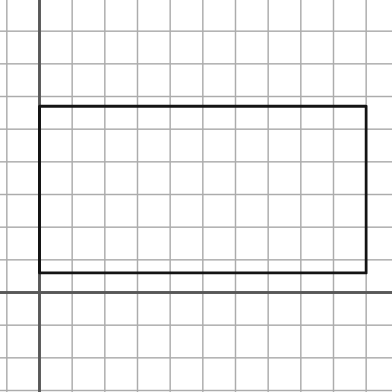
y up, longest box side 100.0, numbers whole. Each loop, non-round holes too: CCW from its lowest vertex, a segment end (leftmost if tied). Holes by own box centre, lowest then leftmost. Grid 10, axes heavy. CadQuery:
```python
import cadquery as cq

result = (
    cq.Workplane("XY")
    .moveTo(0.0, 6.0)
    .lineTo(100.0, 6.0)
    .lineTo(100.0, 57.0)
    .lineTo(0.0, 57.0)
    .close()
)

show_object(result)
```